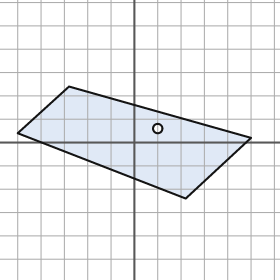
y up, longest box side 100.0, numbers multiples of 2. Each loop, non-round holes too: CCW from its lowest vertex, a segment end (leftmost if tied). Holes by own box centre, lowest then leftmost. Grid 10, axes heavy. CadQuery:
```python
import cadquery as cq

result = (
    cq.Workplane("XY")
    .moveTo(22.0, -24.0)
    .lineTo(50.0, 2.0)
    .lineTo(-28.0, 24.0)
    .lineTo(-50.0, 4.0)
    .close()
    .moveTo(10.0, 6.0)
    .circle(2.0)
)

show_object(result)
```